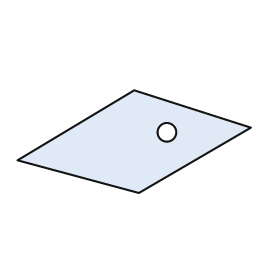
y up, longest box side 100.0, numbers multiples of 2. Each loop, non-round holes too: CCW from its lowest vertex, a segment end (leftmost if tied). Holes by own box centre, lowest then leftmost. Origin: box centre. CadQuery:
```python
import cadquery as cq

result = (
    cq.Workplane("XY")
    .moveTo(2.0, -22.0)
    .lineTo(50.0, 6.0)
    .lineTo(0.0, 22.0)
    .lineTo(-50.0, -8.0)
    .close()
    .moveTo(14.0, 4.0)
    .circle(4.0)
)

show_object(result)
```